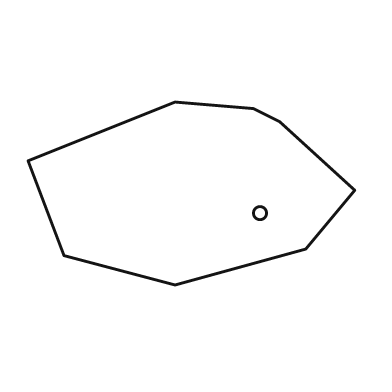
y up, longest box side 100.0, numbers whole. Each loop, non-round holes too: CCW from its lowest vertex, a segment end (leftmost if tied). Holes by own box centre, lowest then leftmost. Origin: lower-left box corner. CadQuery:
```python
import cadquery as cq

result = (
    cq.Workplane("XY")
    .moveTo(45.0, 0.0)
    .lineTo(85.0, 11.0)
    .lineTo(100.0, 29.0)
    .lineTo(77.0, 50.0)
    .lineTo(69.0, 54.0)
    .lineTo(45.0, 56.0)
    .lineTo(0.0, 38.0)
    .lineTo(11.0, 9.0)
    .close()
    .moveTo(71.0, 22.0)
    .circle(2.0)
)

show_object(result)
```